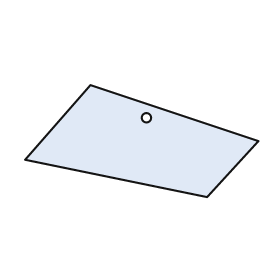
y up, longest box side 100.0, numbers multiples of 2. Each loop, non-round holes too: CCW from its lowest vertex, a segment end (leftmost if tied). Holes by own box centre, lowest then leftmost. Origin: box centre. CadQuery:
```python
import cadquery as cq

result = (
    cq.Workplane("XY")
    .moveTo(28.0, -24.0)
    .lineTo(50.0, 0.0)
    .lineTo(-22.0, 24.0)
    .lineTo(-50.0, -8.0)
    .close()
    .moveTo(2.0, 10.0)
    .circle(2.0)
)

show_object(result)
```